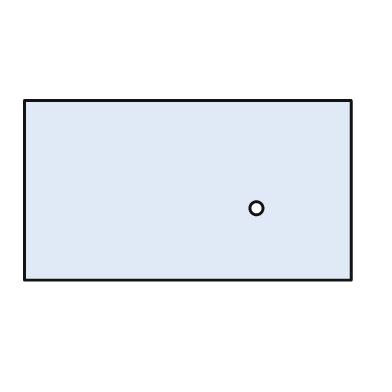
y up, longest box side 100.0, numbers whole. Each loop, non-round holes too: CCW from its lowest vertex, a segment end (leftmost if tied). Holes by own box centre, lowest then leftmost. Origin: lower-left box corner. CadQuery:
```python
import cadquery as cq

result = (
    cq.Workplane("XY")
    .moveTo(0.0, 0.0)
    .lineTo(100.0, 0.0)
    .lineTo(100.0, 55.0)
    .lineTo(0.0, 55.0)
    .close()
    .moveTo(71.0, 22.0)
    .circle(2.0)
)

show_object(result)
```